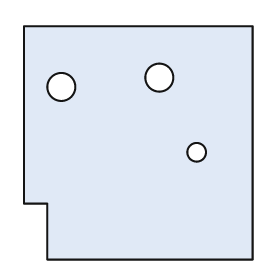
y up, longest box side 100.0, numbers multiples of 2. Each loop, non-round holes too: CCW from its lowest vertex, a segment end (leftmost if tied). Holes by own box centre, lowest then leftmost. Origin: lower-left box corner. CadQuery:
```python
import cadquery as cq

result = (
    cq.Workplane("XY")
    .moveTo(10.0, 0.0)
    .lineTo(98.0, 0.0)
    .lineTo(98.0, 100.0)
    .lineTo(0.0, 100.0)
    .lineTo(0.0, 24.0)
    .lineTo(10.0, 24.0)
    .close()
    .moveTo(74.0, 46.0)
    .circle(4.0)
    .moveTo(16.0, 74.0)
    .circle(6.0)
    .moveTo(58.0, 78.0)
    .circle(6.0)
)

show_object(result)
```